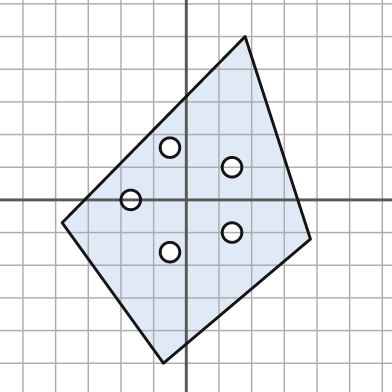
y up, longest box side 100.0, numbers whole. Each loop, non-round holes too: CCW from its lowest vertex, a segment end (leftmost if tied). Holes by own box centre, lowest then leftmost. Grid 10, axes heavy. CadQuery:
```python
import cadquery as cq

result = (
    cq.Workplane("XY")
    .moveTo(-7.0, -50.0)
    .lineTo(38.0, -12.0)
    .lineTo(18.0, 50.0)
    .lineTo(-38.0, -7.0)
    .close()
    .moveTo(-5.0, -16.0)
    .circle(3.0)
    .moveTo(14.0, -10.0)
    .circle(3.0)
    .moveTo(-17.0, 0.0)
    .circle(3.0)
    .moveTo(14.0, 10.0)
    .circle(3.0)
    .moveTo(-5.0, 16.0)
    .circle(3.0)
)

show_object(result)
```